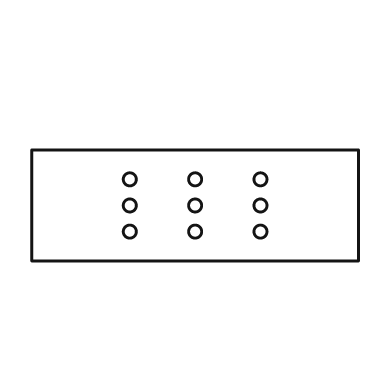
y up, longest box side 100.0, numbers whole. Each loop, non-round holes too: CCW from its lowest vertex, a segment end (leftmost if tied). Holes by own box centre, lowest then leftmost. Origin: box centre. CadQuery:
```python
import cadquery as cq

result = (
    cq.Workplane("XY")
    .moveTo(-50.0, -17.0)
    .lineTo(50.0, -17.0)
    .lineTo(50.0, 17.0)
    .lineTo(-50.0, 17.0)
    .close()
    .moveTo(-20.0, -8.0)
    .circle(2.0)
    .moveTo(0.0, -8.0)
    .circle(2.0)
    .moveTo(20.0, -8.0)
    .circle(2.0)
    .moveTo(-20.0, 0.0)
    .circle(2.0)
    .moveTo(0.0, 0.0)
    .circle(2.0)
    .moveTo(20.0, 0.0)
    .circle(2.0)
    .moveTo(-20.0, 8.0)
    .circle(2.0)
    .moveTo(0.0, 8.0)
    .circle(2.0)
    .moveTo(20.0, 8.0)
    .circle(2.0)
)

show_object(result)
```